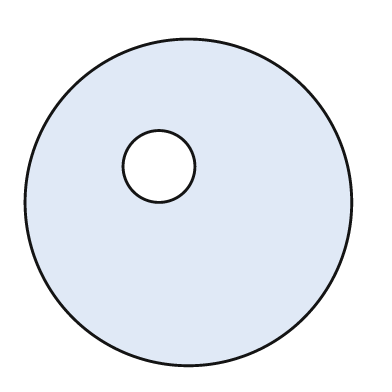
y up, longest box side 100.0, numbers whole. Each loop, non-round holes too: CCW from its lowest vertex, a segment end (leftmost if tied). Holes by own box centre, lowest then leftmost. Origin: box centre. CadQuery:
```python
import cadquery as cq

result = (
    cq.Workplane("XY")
    .moveTo(0.0, 0.0)
    .circle(50.0)
    .moveTo(-9.0, 11.0)
    .circle(11.0)
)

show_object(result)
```